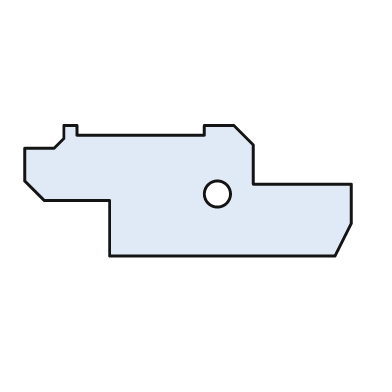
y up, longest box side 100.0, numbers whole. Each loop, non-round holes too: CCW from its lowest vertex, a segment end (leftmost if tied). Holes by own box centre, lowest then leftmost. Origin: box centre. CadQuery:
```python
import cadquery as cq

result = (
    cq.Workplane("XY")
    .moveTo(-24.0, -20.0)
    .lineTo(45.0, -20.0)
    .lineTo(50.0, -10.0)
    .lineTo(50.0, 2.0)
    .lineTo(20.0, 2.0)
    .lineTo(20.0, 14.0)
    .lineTo(14.0, 20.0)
    .lineTo(5.0, 20.0)
    .lineTo(5.0, 17.0)
    .lineTo(-34.0, 17.0)
    .lineTo(-34.0, 20.0)
    .lineTo(-38.0, 20.0)
    .lineTo(-38.0, 16.0)
    .lineTo(-41.0, 13.0)
    .lineTo(-50.0, 13.0)
    .lineTo(-50.0, 3.0)
    .lineTo(-44.0, -3.0)
    .lineTo(-24.0, -3.0)
    .close()
    .moveTo(9.0, -1.0)
    .circle(4.0)
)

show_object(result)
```